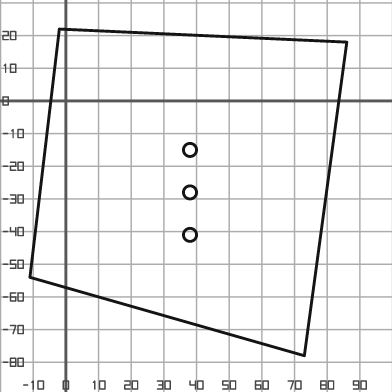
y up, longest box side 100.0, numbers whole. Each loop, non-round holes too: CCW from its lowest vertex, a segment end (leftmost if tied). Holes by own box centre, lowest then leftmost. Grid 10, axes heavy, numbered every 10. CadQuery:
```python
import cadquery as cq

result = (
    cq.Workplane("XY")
    .moveTo(73.0, -78.0)
    .lineTo(86.0, 18.0)
    .lineTo(-2.0, 22.0)
    .lineTo(-11.0, -54.0)
    .close()
    .moveTo(38.0, -41.0)
    .circle(2.0)
    .moveTo(38.0, -28.0)
    .circle(2.0)
    .moveTo(38.0, -15.0)
    .circle(2.0)
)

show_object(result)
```